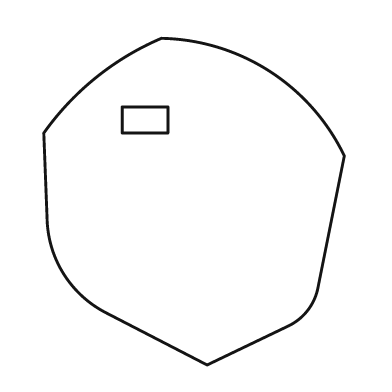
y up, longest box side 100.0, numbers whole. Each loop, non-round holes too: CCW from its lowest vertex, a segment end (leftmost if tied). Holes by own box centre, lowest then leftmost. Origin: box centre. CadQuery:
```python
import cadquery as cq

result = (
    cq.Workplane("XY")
    .moveTo(4.0, -50.0)
    .lineTo(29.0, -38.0)
    .threePointArc((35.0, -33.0), (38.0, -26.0))
    .lineTo(46.0, 14.0)
    .threePointArc((23.0, 40.0), (-10.0, 50.0))
    .threePointArc((-30.0, 38.0), (-46.0, 21.0))
    .lineTo(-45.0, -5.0)
    .threePointArc((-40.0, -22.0), (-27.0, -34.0))
    .close()
    .moveTo(-22.0, 21.0)
    .lineTo(-8.0, 21.0)
    .lineTo(-8.0, 29.0)
    .lineTo(-22.0, 29.0)
    .close()
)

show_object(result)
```